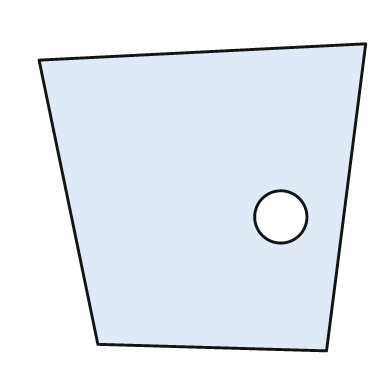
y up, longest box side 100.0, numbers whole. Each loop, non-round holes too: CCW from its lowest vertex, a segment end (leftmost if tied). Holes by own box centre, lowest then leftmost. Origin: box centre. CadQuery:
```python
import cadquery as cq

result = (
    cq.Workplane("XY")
    .moveTo(38.0, -47.0)
    .lineTo(50.0, 47.0)
    .lineTo(-50.0, 42.0)
    .lineTo(-32.0, -45.0)
    .close()
    .moveTo(24.0, -6.0)
    .circle(8.0)
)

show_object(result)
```